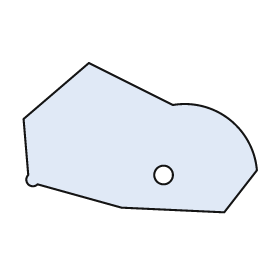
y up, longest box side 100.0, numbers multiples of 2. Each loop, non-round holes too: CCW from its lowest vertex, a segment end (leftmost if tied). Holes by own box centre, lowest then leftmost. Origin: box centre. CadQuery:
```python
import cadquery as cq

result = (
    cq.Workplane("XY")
    .moveTo(36.0, -32.0)
    .lineTo(50.0, -14.0)
    .threePointArc((38.0, 8.0), (14.0, 14.0))
    .lineTo(-22.0, 32.0)
    .lineTo(-50.0, 8.0)
    .lineTo(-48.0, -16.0)
    .threePointArc((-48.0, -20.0), (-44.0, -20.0))
    .lineTo(-8.0, -30.0)
    .close()
    .moveTo(10.0, -16.0)
    .circle(4.0)
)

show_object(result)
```